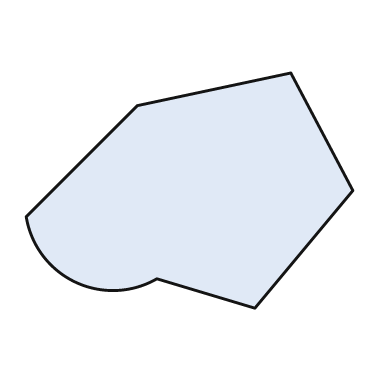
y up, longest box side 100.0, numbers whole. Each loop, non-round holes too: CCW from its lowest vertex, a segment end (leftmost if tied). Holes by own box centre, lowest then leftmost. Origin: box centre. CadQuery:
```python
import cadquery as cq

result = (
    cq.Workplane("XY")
    .moveTo(20.0, -36.0)
    .lineTo(50.0, 0.0)
    .lineTo(31.0, 36.0)
    .lineTo(-16.0, 26.0)
    .lineTo(-50.0, -8.0)
    .threePointArc((-35.0, -28.0), (-10.0, -27.0))
    .close()
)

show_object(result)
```